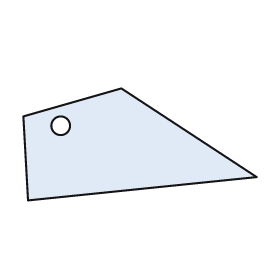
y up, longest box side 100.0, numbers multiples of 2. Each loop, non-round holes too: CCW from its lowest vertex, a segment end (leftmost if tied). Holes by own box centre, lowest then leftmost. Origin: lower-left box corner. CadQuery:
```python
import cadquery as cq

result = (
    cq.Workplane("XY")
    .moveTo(2.0, 0.0)
    .lineTo(100.0, 10.0)
    .lineTo(42.0, 48.0)
    .lineTo(0.0, 36.0)
    .close()
    .moveTo(16.0, 32.0)
    .circle(4.0)
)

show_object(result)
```